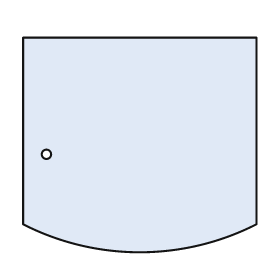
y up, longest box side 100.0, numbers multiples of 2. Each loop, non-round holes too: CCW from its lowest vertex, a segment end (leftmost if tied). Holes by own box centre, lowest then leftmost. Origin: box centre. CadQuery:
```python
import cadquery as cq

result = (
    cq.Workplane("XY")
    .moveTo(-50.0, -34.0)
    .threePointArc((0.0, -46.0), (50.0, -34.0))
    .lineTo(50.0, 46.0)
    .lineTo(-50.0, 46.0)
    .close()
    .moveTo(-40.0, -4.0)
    .circle(2.0)
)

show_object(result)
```